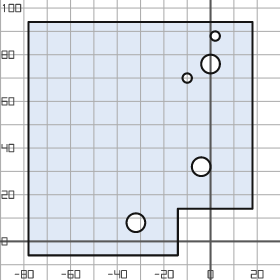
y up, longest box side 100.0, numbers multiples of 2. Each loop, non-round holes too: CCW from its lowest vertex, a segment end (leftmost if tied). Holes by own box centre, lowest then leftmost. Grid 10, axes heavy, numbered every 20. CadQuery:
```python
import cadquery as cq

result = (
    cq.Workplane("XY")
    .moveTo(-78.0, -6.0)
    .lineTo(-14.0, -6.0)
    .lineTo(-14.0, 14.0)
    .lineTo(18.0, 14.0)
    .lineTo(18.0, 94.0)
    .lineTo(-78.0, 94.0)
    .close()
    .moveTo(-32.0, 8.0)
    .circle(4.0)
    .moveTo(-4.0, 32.0)
    .circle(4.0)
    .moveTo(-10.0, 70.0)
    .circle(2.0)
    .moveTo(0.0, 76.0)
    .circle(4.0)
    .moveTo(2.0, 88.0)
    .circle(2.0)
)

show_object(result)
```